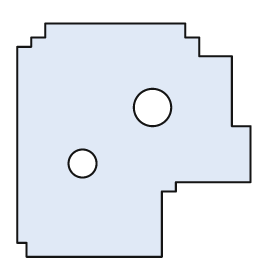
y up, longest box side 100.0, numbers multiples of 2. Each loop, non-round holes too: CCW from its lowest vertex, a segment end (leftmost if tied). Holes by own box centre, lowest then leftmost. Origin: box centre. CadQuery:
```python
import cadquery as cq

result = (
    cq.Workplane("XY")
    .moveTo(-46.0, -50.0)
    .lineTo(12.0, -50.0)
    .lineTo(12.0, -22.0)
    .lineTo(18.0, -22.0)
    .lineTo(18.0, -18.0)
    .lineTo(50.0, -18.0)
    .lineTo(50.0, 6.0)
    .lineTo(42.0, 6.0)
    .lineTo(42.0, 36.0)
    .lineTo(28.0, 36.0)
    .lineTo(28.0, 44.0)
    .lineTo(22.0, 44.0)
    .lineTo(22.0, 50.0)
    .lineTo(-38.0, 50.0)
    .lineTo(-38.0, 44.0)
    .lineTo(-44.0, 44.0)
    .lineTo(-44.0, 40.0)
    .lineTo(-50.0, 40.0)
    .lineTo(-50.0, -44.0)
    .lineTo(-46.0, -44.0)
    .close()
    .moveTo(-22.0, -10.0)
    .circle(6.0)
    .moveTo(8.0, 14.0)
    .circle(8.0)
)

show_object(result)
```